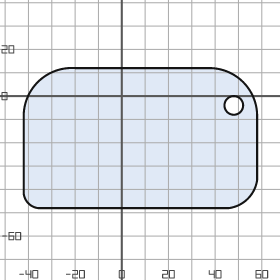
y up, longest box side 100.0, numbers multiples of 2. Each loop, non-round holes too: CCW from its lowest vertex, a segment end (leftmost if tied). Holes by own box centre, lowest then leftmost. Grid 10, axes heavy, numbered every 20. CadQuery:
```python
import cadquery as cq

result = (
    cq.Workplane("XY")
    .moveTo(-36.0, -48.0)
    .lineTo(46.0, -48.0)
    .threePointArc((54.0, -44.0), (58.0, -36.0))
    .lineTo(58.0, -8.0)
    .threePointArc((52.0, 6.0), (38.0, 12.0))
    .lineTo(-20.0, 12.0)
    .threePointArc((-36.0, 6.0), (-42.0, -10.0))
    .lineTo(-42.0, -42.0)
    .threePointArc((-40.0, -46.0), (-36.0, -48.0))
    .close()
    .moveTo(48.0, -4.0)
    .circle(4.0)
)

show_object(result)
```